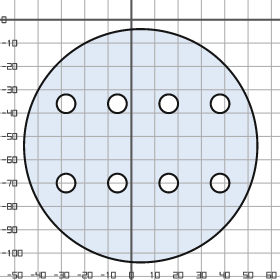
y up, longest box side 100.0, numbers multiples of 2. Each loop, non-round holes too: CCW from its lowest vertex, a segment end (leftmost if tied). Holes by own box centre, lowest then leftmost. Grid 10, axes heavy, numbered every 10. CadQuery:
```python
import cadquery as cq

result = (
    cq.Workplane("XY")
    .moveTo(4.0, -54.0)
    .circle(50.0)
    .moveTo(-28.0, -70.0)
    .circle(4.0)
    .moveTo(-6.0, -70.0)
    .circle(4.0)
    .moveTo(16.0, -70.0)
    .circle(4.0)
    .moveTo(38.0, -70.0)
    .circle(4.0)
    .moveTo(-28.0, -36.0)
    .circle(4.0)
    .moveTo(-6.0, -36.0)
    .circle(4.0)
    .moveTo(16.0, -36.0)
    .circle(4.0)
    .moveTo(38.0, -36.0)
    .circle(4.0)
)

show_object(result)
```